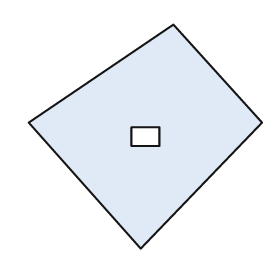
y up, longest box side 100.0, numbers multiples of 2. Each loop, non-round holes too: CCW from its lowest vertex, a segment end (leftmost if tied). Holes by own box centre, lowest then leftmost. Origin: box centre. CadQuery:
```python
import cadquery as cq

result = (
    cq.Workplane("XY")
    .moveTo(-2.0, -48.0)
    .lineTo(50.0, 6.0)
    .lineTo(12.0, 48.0)
    .lineTo(-50.0, 6.0)
    .close()
    .moveTo(-6.0, -4.0)
    .lineTo(6.0, -4.0)
    .lineTo(6.0, 4.0)
    .lineTo(-6.0, 4.0)
    .close()
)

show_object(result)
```